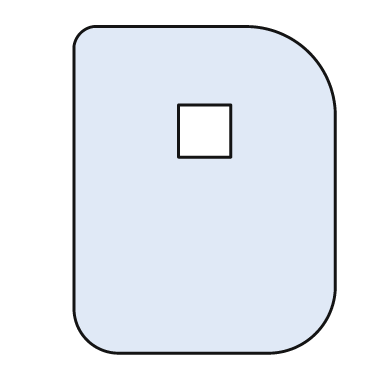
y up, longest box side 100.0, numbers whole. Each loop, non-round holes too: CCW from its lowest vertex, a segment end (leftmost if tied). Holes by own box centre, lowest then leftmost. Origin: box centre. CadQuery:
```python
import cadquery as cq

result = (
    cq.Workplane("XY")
    .moveTo(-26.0, -50.0)
    .lineTo(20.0, -50.0)
    .threePointArc((34.0, -44.0), (40.0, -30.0))
    .lineTo(40.0, 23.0)
    .threePointArc((32.0, 42.0), (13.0, 50.0))
    .lineTo(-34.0, 50.0)
    .threePointArc((-38.0, 48.0), (-40.0, 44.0))
    .lineTo(-40.0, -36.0)
    .threePointArc((-36.0, -46.0), (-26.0, -50.0))
    .close()
    .moveTo(-8.0, 10.0)
    .lineTo(8.0, 10.0)
    .lineTo(8.0, 26.0)
    .lineTo(-8.0, 26.0)
    .close()
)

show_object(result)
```